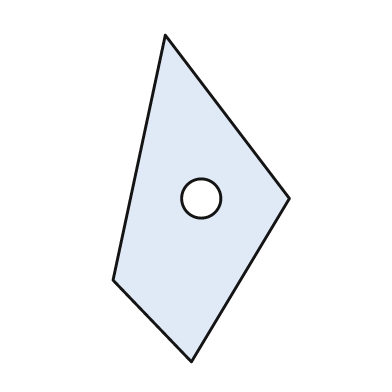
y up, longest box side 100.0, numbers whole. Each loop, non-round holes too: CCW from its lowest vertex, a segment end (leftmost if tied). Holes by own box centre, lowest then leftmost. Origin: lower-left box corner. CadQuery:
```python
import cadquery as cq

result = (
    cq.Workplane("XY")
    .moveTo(24.0, 0.0)
    .lineTo(54.0, 50.0)
    .lineTo(16.0, 100.0)
    .lineTo(0.0, 25.0)
    .close()
    .moveTo(27.0, 50.0)
    .circle(6.0)
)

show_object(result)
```